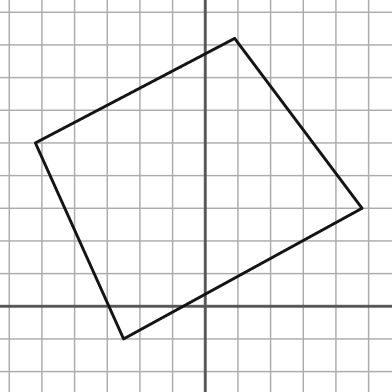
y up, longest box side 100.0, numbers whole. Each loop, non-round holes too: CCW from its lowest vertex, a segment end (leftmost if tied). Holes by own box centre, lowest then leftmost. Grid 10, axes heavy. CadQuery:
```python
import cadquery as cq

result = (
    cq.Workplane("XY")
    .moveTo(-25.0, -10.0)
    .lineTo(48.0, 30.0)
    .lineTo(9.0, 82.0)
    .lineTo(-52.0, 50.0)
    .close()
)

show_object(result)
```